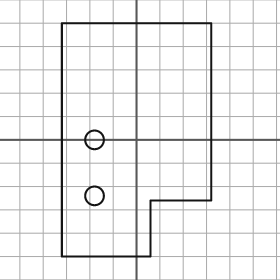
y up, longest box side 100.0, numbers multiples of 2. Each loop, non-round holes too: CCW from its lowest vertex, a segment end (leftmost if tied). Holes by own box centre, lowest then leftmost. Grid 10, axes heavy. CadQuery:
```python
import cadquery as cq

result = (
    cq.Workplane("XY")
    .moveTo(-32.0, -50.0)
    .lineTo(6.0, -50.0)
    .lineTo(6.0, -26.0)
    .lineTo(32.0, -26.0)
    .lineTo(32.0, 50.0)
    .lineTo(-32.0, 50.0)
    .close()
    .moveTo(-18.0, -24.0)
    .circle(4.0)
    .moveTo(-18.0, 0.0)
    .circle(4.0)
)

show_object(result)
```